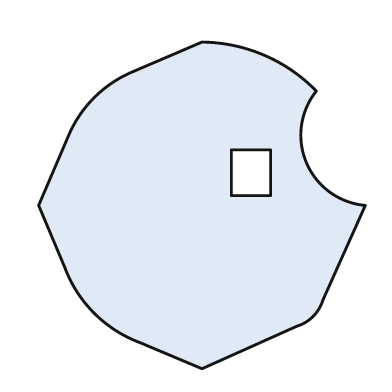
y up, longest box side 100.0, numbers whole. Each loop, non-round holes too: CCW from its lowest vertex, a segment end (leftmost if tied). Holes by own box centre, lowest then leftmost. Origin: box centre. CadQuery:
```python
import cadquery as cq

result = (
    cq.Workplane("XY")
    .moveTo(0.0, -50.0)
    .lineTo(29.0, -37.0)
    .threePointArc((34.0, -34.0), (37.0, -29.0))
    .lineTo(50.0, 0.0)
    .threePointArc((32.0, 13.0), (35.0, 35.0))
    .threePointArc((19.0, 46.0), (0.0, 50.0))
    .lineTo(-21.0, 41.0)
    .threePointArc((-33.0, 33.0), (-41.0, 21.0))
    .lineTo(-50.0, 0.0)
    .lineTo(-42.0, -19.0)
    .threePointArc((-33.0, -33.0), (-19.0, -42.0))
    .close()
    .moveTo(9.0, 3.0)
    .lineTo(21.0, 3.0)
    .lineTo(21.0, 17.0)
    .lineTo(9.0, 17.0)
    .close()
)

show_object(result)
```